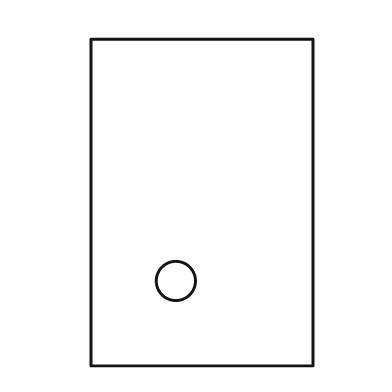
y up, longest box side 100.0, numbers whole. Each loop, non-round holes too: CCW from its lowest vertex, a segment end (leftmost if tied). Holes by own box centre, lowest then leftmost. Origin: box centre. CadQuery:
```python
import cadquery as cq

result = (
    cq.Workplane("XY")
    .moveTo(-34.0, -50.0)
    .lineTo(34.0, -50.0)
    .lineTo(34.0, 50.0)
    .lineTo(-34.0, 50.0)
    .close()
    .moveTo(-8.0, -24.0)
    .circle(6.0)
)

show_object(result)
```